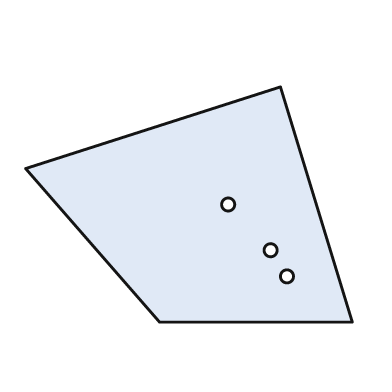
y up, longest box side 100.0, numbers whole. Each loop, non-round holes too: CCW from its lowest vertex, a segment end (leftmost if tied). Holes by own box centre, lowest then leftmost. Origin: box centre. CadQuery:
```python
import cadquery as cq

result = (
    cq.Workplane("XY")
    .moveTo(-9.0, -36.0)
    .lineTo(50.0, -36.0)
    .lineTo(28.0, 36.0)
    .lineTo(-50.0, 11.0)
    .close()
    .moveTo(30.0, -22.0)
    .circle(2.0)
    .moveTo(25.0, -14.0)
    .circle(2.0)
    .moveTo(12.0, 0.0)
    .circle(2.0)
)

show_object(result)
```